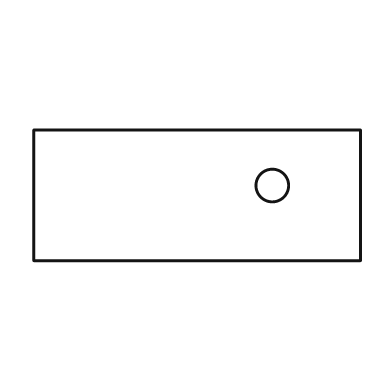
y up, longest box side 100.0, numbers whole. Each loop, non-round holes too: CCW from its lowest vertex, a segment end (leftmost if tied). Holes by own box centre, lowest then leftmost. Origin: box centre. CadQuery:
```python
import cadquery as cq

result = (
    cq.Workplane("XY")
    .moveTo(-50.0, -20.0)
    .lineTo(50.0, -20.0)
    .lineTo(50.0, 20.0)
    .lineTo(-50.0, 20.0)
    .close()
    .moveTo(23.0, 3.0)
    .circle(5.0)
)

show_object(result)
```